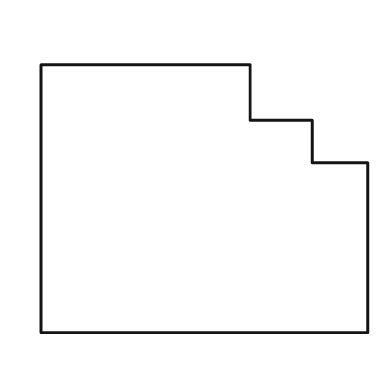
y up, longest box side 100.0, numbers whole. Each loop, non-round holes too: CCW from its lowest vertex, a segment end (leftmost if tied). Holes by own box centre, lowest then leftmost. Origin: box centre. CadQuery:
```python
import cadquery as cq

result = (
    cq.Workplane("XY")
    .moveTo(-50.0, -41.0)
    .lineTo(50.0, -41.0)
    .lineTo(50.0, 11.0)
    .lineTo(33.0, 11.0)
    .lineTo(33.0, 24.0)
    .lineTo(14.0, 24.0)
    .lineTo(14.0, 41.0)
    .lineTo(-50.0, 41.0)
    .close()
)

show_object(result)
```